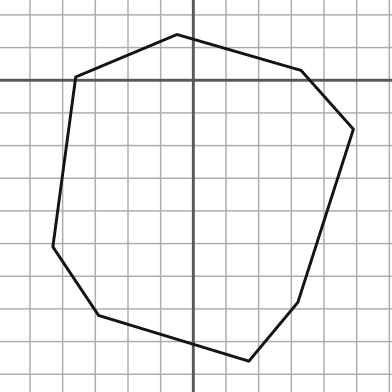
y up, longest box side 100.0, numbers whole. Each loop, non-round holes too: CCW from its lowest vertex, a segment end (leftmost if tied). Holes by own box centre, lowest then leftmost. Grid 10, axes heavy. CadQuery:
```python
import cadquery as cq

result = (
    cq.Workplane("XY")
    .moveTo(17.0, -86.0)
    .lineTo(32.0, -68.0)
    .lineTo(49.0, -15.0)
    .lineTo(33.0, 3.0)
    .lineTo(-5.0, 14.0)
    .lineTo(-36.0, 1.0)
    .lineTo(-43.0, -51.0)
    .lineTo(-29.0, -72.0)
    .close()
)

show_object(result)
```